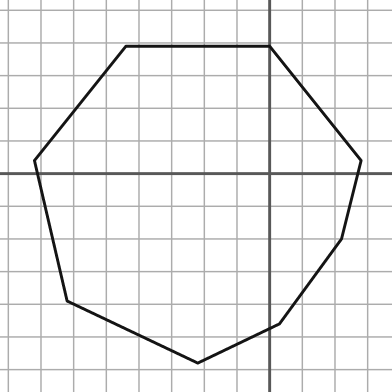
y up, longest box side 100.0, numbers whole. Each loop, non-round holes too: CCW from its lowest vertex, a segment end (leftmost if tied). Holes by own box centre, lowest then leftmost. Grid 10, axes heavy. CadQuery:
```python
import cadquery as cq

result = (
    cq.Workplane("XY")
    .moveTo(-22.0, -58.0)
    .lineTo(3.0, -46.0)
    .lineTo(22.0, -20.0)
    .lineTo(28.0, 4.0)
    .lineTo(0.0, 39.0)
    .lineTo(-44.0, 39.0)
    .lineTo(-72.0, 4.0)
    .lineTo(-62.0, -39.0)
    .close()
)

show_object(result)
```